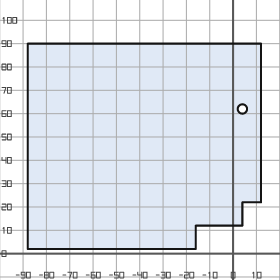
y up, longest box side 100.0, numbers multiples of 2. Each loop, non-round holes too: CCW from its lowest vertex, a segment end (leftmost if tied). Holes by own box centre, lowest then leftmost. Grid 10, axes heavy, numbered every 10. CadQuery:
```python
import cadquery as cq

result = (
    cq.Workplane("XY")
    .moveTo(-88.0, 2.0)
    .lineTo(-16.0, 2.0)
    .lineTo(-16.0, 12.0)
    .lineTo(4.0, 12.0)
    .lineTo(4.0, 22.0)
    .lineTo(12.0, 22.0)
    .lineTo(12.0, 90.0)
    .lineTo(-88.0, 90.0)
    .close()
    .moveTo(4.0, 62.0)
    .circle(2.0)
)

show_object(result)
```